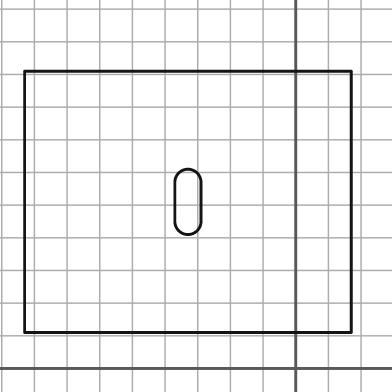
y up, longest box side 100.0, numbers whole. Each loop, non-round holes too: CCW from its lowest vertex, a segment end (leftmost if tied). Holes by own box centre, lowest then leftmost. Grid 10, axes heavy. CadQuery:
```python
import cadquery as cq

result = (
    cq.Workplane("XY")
    .moveTo(-83.0, 11.0)
    .lineTo(17.0, 11.0)
    .lineTo(17.0, 91.0)
    .lineTo(-83.0, 91.0)
    .close()
    .moveTo(-37.0, 45.0)
    .threePointArc((-33.0, 41.0), (-29.0, 45.0))
    .lineTo(-29.0, 57.0)
    .threePointArc((-33.0, 61.0), (-37.0, 57.0))
    .close()
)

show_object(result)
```